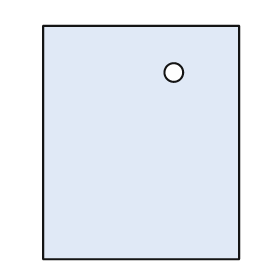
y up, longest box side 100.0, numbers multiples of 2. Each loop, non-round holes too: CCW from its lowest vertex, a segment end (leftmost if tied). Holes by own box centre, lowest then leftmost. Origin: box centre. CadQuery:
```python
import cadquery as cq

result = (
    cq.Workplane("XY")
    .moveTo(-42.0, -50.0)
    .lineTo(42.0, -50.0)
    .lineTo(42.0, 50.0)
    .lineTo(-42.0, 50.0)
    .close()
    .moveTo(14.0, 30.0)
    .circle(4.0)
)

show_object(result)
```